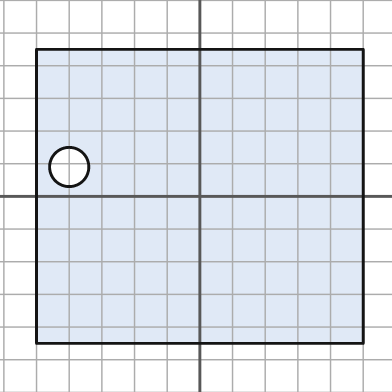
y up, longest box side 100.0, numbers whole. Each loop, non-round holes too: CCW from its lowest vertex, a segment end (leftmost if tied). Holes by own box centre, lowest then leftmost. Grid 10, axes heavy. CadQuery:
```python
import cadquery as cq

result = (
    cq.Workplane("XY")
    .moveTo(-50.0, -45.0)
    .lineTo(50.0, -45.0)
    .lineTo(50.0, 45.0)
    .lineTo(-50.0, 45.0)
    .close()
    .moveTo(-40.0, 9.0)
    .circle(6.0)
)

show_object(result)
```